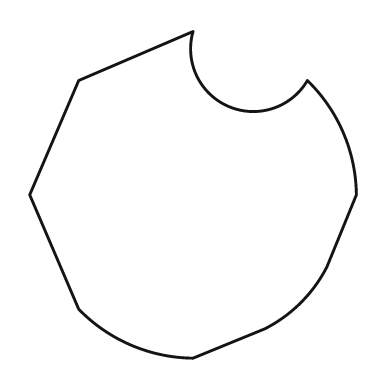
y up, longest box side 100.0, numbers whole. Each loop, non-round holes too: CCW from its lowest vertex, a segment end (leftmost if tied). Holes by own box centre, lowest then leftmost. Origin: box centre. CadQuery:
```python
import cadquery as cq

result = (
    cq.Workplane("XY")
    .moveTo(0.0, -50.0)
    .lineTo(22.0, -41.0)
    .threePointArc((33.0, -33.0), (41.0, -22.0))
    .lineTo(50.0, 0.0)
    .threePointArc((46.0, 19.0), (35.0, 35.0))
    .threePointArc((11.0, 27.0), (0.0, 50.0))
    .lineTo(-35.0, 35.0)
    .lineTo(-50.0, 0.0)
    .lineTo(-35.0, -35.0)
    .threePointArc((-19.0, -46.0), (0.0, -50.0))
    .close()
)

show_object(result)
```